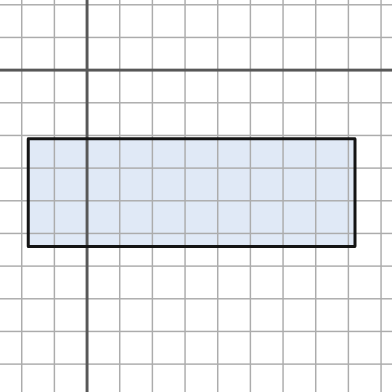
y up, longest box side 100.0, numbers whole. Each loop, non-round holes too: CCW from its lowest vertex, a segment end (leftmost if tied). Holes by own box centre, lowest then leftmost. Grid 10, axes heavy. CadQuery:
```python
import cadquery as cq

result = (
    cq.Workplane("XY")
    .moveTo(-18.0, -54.0)
    .lineTo(82.0, -54.0)
    .lineTo(82.0, -21.0)
    .lineTo(-18.0, -21.0)
    .close()
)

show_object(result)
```